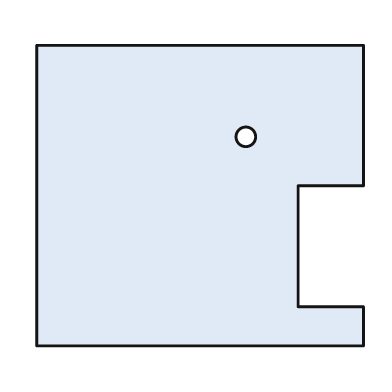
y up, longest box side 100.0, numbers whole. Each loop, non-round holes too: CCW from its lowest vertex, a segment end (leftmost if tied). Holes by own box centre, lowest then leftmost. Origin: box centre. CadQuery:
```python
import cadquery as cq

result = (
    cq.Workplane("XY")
    .moveTo(-50.0, -46.0)
    .lineTo(50.0, -46.0)
    .lineTo(50.0, -34.0)
    .lineTo(30.0, -34.0)
    .lineTo(30.0, 3.0)
    .lineTo(50.0, 3.0)
    .lineTo(50.0, 46.0)
    .lineTo(-50.0, 46.0)
    .close()
    .moveTo(14.0, 18.0)
    .circle(3.0)
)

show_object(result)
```